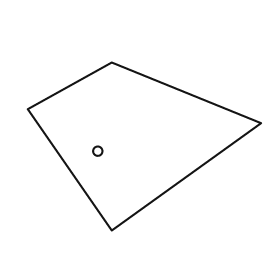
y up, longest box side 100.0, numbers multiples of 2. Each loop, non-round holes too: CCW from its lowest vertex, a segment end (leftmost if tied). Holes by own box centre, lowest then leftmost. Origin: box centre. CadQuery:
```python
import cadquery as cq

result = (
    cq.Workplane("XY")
    .moveTo(-14.0, -36.0)
    .lineTo(50.0, 10.0)
    .lineTo(-14.0, 36.0)
    .lineTo(-50.0, 16.0)
    .close()
    .moveTo(-20.0, -2.0)
    .circle(2.0)
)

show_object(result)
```